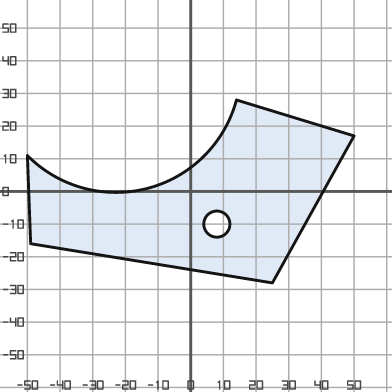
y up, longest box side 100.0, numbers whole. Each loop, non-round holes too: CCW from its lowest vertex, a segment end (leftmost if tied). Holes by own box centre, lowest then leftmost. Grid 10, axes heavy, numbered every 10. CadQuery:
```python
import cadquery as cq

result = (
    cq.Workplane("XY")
    .moveTo(25.0, -28.0)
    .lineTo(50.0, 17.0)
    .lineTo(14.0, 28.0)
    .threePointArc((-13.0, 1.0), (-50.0, 11.0))
    .lineTo(-49.0, -16.0)
    .close()
    .moveTo(8.0, -10.0)
    .circle(4.0)
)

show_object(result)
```